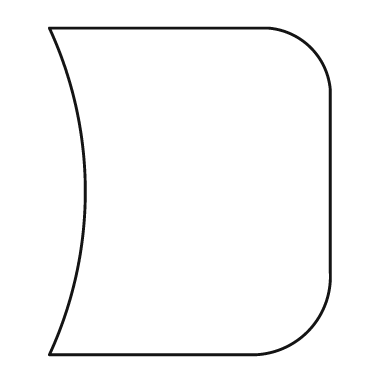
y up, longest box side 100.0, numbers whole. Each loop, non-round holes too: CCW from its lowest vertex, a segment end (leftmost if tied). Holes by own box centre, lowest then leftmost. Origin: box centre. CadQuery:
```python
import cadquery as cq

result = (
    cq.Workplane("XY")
    .moveTo(-43.0, -50.0)
    .lineTo(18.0, -50.0)
    .threePointArc((36.0, -43.0), (43.0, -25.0))
    .lineTo(43.0, 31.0)
    .threePointArc((37.0, 44.0), (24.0, 50.0))
    .lineTo(-43.0, 50.0)
    .threePointArc((-32.0, 0.0), (-43.0, -50.0))
    .close()
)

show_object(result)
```